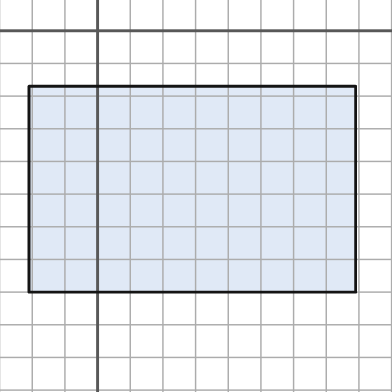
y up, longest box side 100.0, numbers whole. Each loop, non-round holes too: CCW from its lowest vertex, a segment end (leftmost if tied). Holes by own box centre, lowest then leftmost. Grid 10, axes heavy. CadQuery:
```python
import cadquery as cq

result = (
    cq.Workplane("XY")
    .moveTo(-21.0, -80.0)
    .lineTo(79.0, -80.0)
    .lineTo(79.0, -17.0)
    .lineTo(-21.0, -17.0)
    .close()
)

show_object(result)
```